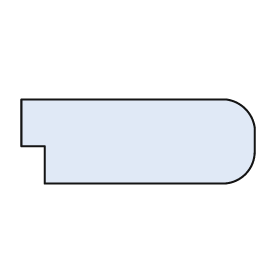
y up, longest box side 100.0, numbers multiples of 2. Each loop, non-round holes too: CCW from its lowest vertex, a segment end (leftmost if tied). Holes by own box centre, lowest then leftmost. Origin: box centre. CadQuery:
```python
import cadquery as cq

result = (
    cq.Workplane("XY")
    .moveTo(-40.0, -18.0)
    .lineTo(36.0, -18.0)
    .threePointArc((46.0, -14.0), (50.0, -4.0))
    .lineTo(50.0, 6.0)
    .threePointArc((46.0, 14.0), (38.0, 18.0))
    .lineTo(-50.0, 18.0)
    .lineTo(-50.0, -2.0)
    .lineTo(-40.0, -2.0)
    .close()
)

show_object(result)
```